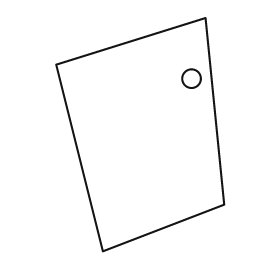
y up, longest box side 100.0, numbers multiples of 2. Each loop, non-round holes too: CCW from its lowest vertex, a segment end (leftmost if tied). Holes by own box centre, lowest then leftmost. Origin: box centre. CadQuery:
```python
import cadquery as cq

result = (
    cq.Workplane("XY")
    .moveTo(-16.0, -50.0)
    .lineTo(36.0, -30.0)
    .lineTo(28.0, 50.0)
    .lineTo(-36.0, 30.0)
    .close()
    .moveTo(22.0, 24.0)
    .circle(4.0)
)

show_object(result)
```